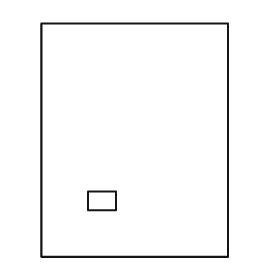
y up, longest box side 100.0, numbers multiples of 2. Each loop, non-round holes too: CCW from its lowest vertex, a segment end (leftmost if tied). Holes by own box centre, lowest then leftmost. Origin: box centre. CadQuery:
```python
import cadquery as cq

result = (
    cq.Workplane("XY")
    .moveTo(-40.0, -50.0)
    .lineTo(40.0, -50.0)
    .lineTo(40.0, 50.0)
    .lineTo(-40.0, 50.0)
    .close()
    .moveTo(-20.0, -30.0)
    .lineTo(-8.0, -30.0)
    .lineTo(-8.0, -22.0)
    .lineTo(-20.0, -22.0)
    .close()
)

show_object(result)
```